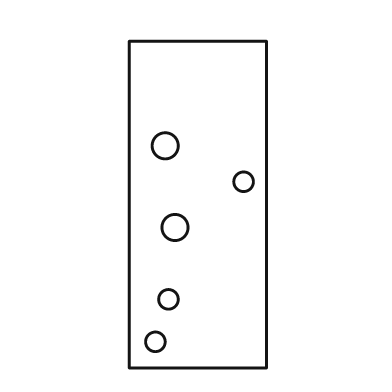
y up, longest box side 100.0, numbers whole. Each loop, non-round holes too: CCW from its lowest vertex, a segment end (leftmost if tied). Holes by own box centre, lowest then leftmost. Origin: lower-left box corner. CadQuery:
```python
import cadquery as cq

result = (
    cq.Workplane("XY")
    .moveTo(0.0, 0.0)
    .lineTo(42.0, 0.0)
    .lineTo(42.0, 100.0)
    .lineTo(0.0, 100.0)
    .close()
    .moveTo(8.0, 8.0)
    .circle(3.0)
    .moveTo(12.0, 21.0)
    .circle(3.0)
    .moveTo(14.0, 43.0)
    .circle(4.0)
    .moveTo(35.0, 57.0)
    .circle(3.0)
    .moveTo(11.0, 68.0)
    .circle(4.0)
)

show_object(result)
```